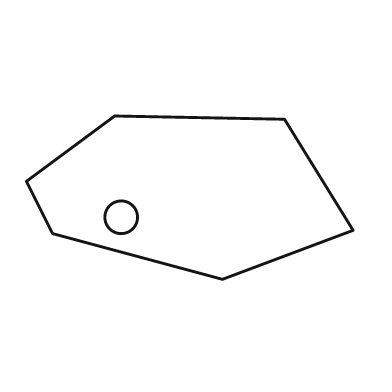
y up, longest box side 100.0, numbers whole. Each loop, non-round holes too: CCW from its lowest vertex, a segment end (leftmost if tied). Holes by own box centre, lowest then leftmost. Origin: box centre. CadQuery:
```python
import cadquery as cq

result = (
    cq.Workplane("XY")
    .moveTo(10.0, -25.0)
    .lineTo(50.0, -10.0)
    .lineTo(29.0, 24.0)
    .lineTo(-23.0, 25.0)
    .lineTo(-50.0, 5.0)
    .lineTo(-42.0, -11.0)
    .close()
    .moveTo(-21.0, -6.0)
    .circle(5.0)
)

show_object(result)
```